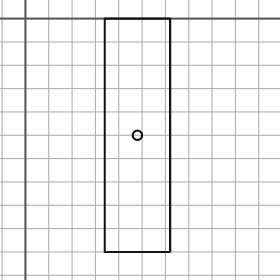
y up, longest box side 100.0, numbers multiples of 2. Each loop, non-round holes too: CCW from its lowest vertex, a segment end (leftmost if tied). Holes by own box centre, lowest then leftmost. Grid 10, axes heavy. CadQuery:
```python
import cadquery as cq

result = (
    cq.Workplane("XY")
    .moveTo(34.0, -100.0)
    .lineTo(62.0, -100.0)
    .lineTo(62.0, 0.0)
    .lineTo(34.0, 0.0)
    .close()
    .moveTo(48.0, -50.0)
    .circle(2.0)
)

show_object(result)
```